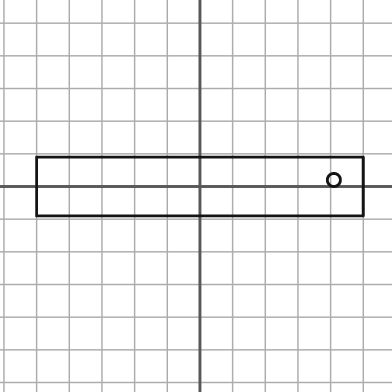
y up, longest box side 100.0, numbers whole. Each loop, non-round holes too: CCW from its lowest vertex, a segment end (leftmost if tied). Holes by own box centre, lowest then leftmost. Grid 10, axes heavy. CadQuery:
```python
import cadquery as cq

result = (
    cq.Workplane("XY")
    .moveTo(-50.0, -9.0)
    .lineTo(50.0, -9.0)
    .lineTo(50.0, 9.0)
    .lineTo(-50.0, 9.0)
    .close()
    .moveTo(41.0, 2.0)
    .circle(2.0)
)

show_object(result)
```